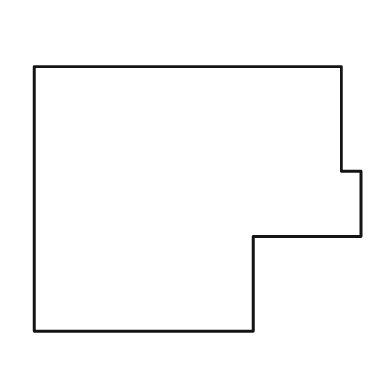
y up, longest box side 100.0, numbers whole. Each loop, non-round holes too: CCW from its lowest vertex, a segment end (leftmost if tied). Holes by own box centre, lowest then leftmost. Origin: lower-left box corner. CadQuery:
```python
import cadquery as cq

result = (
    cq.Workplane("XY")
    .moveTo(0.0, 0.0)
    .lineTo(67.0, 0.0)
    .lineTo(67.0, 29.0)
    .lineTo(100.0, 29.0)
    .lineTo(100.0, 49.0)
    .lineTo(94.0, 49.0)
    .lineTo(94.0, 81.0)
    .lineTo(0.0, 81.0)
    .close()
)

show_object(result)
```